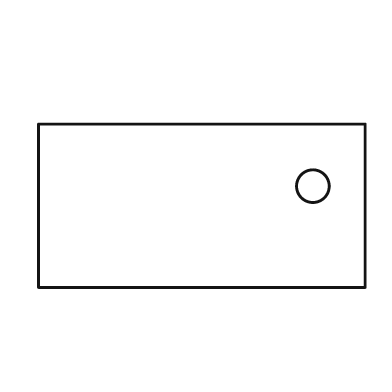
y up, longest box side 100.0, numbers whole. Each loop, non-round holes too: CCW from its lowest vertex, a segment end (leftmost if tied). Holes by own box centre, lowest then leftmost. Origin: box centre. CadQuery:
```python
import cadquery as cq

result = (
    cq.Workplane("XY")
    .moveTo(-50.0, -25.0)
    .lineTo(50.0, -25.0)
    .lineTo(50.0, 25.0)
    .lineTo(-50.0, 25.0)
    .close()
    .moveTo(34.0, 6.0)
    .circle(5.0)
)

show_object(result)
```